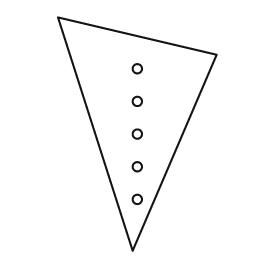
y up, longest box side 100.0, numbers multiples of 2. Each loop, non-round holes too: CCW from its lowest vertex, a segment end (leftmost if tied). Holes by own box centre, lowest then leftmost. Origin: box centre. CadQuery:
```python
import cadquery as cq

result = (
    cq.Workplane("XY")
    .moveTo(-2.0, -50.0)
    .lineTo(34.0, 34.0)
    .lineTo(-34.0, 50.0)
    .close()
    .moveTo(0.0, -28.0)
    .circle(2.0)
    .moveTo(0.0, -14.0)
    .circle(2.0)
    .moveTo(0.0, 0.0)
    .circle(2.0)
    .moveTo(0.0, 14.0)
    .circle(2.0)
    .moveTo(0.0, 28.0)
    .circle(2.0)
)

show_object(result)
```